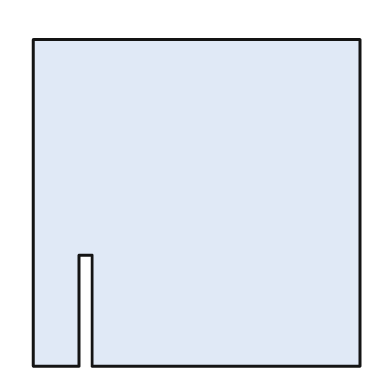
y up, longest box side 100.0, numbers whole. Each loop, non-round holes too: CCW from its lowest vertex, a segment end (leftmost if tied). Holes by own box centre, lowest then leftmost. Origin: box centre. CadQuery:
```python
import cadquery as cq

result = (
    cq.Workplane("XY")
    .moveTo(-50.0, -50.0)
    .lineTo(-36.0, -50.0)
    .lineTo(-36.0, -16.0)
    .lineTo(-32.0, -16.0)
    .lineTo(-32.0, -50.0)
    .lineTo(50.0, -50.0)
    .lineTo(50.0, 50.0)
    .lineTo(-50.0, 50.0)
    .close()
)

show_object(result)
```